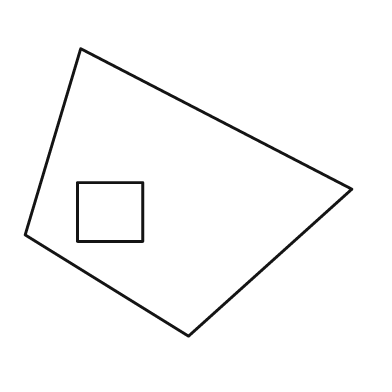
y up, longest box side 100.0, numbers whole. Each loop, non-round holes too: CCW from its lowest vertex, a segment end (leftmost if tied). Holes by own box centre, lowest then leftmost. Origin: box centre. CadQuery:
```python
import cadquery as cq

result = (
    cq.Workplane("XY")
    .moveTo(0.0, -44.0)
    .lineTo(50.0, 1.0)
    .lineTo(-33.0, 44.0)
    .lineTo(-50.0, -13.0)
    .close()
    .moveTo(-34.0, -15.0)
    .lineTo(-14.0, -15.0)
    .lineTo(-14.0, 3.0)
    .lineTo(-34.0, 3.0)
    .close()
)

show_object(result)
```